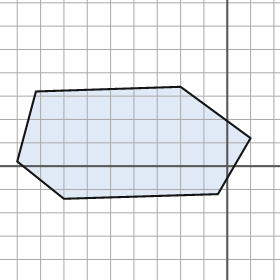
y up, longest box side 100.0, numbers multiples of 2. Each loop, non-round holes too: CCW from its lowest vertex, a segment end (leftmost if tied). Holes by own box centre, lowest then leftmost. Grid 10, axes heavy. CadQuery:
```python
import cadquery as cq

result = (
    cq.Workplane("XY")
    .moveTo(-70.0, -14.0)
    .lineTo(-4.0, -12.0)
    .lineTo(10.0, 12.0)
    .lineTo(-20.0, 34.0)
    .lineTo(-82.0, 32.0)
    .lineTo(-90.0, 2.0)
    .close()
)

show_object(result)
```